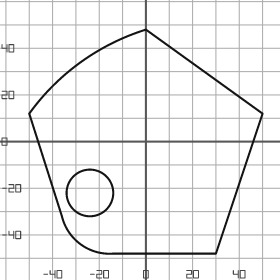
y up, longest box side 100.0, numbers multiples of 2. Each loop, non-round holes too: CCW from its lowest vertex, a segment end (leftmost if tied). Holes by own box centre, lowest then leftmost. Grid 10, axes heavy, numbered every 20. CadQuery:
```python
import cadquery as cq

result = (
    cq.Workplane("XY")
    .moveTo(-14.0, -48.0)
    .lineTo(30.0, -48.0)
    .lineTo(50.0, 12.0)
    .lineTo(0.0, 48.0)
    .threePointArc((-28.0, 34.0), (-50.0, 12.0))
    .lineTo(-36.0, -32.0)
    .threePointArc((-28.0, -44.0), (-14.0, -48.0))
    .close()
    .moveTo(-24.0, -22.0)
    .circle(10.0)
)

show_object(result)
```